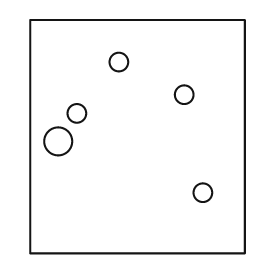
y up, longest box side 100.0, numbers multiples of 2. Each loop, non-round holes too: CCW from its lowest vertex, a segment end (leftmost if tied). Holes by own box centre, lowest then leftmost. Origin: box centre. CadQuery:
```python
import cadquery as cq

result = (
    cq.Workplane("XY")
    .moveTo(-46.0, -50.0)
    .lineTo(46.0, -50.0)
    .lineTo(46.0, 50.0)
    .lineTo(-46.0, 50.0)
    .close()
    .moveTo(28.0, -24.0)
    .circle(4.0)
    .moveTo(-34.0, -2.0)
    .circle(6.0)
    .moveTo(-26.0, 10.0)
    .circle(4.0)
    .moveTo(20.0, 18.0)
    .circle(4.0)
    .moveTo(-8.0, 32.0)
    .circle(4.0)
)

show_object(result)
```